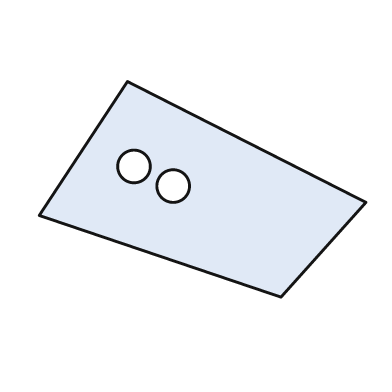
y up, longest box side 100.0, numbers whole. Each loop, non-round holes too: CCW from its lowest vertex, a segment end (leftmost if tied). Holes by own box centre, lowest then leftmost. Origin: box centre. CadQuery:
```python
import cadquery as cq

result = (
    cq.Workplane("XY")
    .moveTo(24.0, -33.0)
    .lineTo(50.0, -4.0)
    .lineTo(-23.0, 33.0)
    .lineTo(-50.0, -8.0)
    .close()
    .moveTo(-9.0, 1.0)
    .circle(5.0)
    .moveTo(-21.0, 7.0)
    .circle(5.0)
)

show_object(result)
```